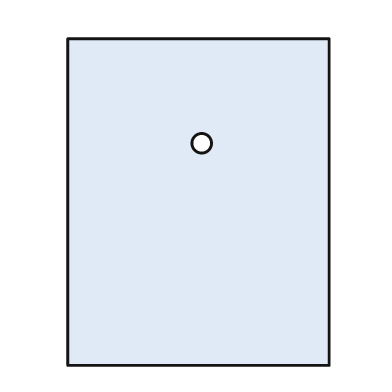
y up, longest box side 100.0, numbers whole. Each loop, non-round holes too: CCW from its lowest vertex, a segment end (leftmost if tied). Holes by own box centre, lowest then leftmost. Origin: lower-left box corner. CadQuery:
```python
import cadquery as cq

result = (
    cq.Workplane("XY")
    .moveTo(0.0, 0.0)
    .lineTo(80.0, 0.0)
    .lineTo(80.0, 100.0)
    .lineTo(0.0, 100.0)
    .close()
    .moveTo(41.0, 68.0)
    .circle(3.0)
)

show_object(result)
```